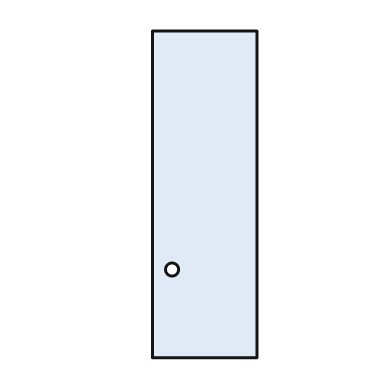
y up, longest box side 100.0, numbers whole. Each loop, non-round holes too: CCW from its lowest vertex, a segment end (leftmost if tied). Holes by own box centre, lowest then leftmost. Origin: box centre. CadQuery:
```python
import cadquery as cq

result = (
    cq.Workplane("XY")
    .moveTo(-16.0, -50.0)
    .lineTo(16.0, -50.0)
    .lineTo(16.0, 50.0)
    .lineTo(-16.0, 50.0)
    .close()
    .moveTo(-10.0, -23.0)
    .circle(2.0)
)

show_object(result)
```